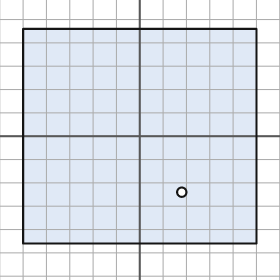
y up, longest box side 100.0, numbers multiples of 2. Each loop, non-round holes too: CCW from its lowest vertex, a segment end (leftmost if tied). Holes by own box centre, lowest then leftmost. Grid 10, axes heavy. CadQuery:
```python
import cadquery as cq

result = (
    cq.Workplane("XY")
    .moveTo(-50.0, -46.0)
    .lineTo(50.0, -46.0)
    .lineTo(50.0, 46.0)
    .lineTo(-50.0, 46.0)
    .close()
    .moveTo(18.0, -24.0)
    .circle(2.0)
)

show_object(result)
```